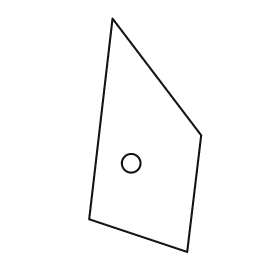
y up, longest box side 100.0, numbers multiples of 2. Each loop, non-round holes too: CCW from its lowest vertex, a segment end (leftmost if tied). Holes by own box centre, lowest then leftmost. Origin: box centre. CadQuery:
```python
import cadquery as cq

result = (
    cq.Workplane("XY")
    .moveTo(18.0, -50.0)
    .lineTo(24.0, 0.0)
    .lineTo(-14.0, 50.0)
    .lineTo(-24.0, -36.0)
    .close()
    .moveTo(-6.0, -12.0)
    .circle(4.0)
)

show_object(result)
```